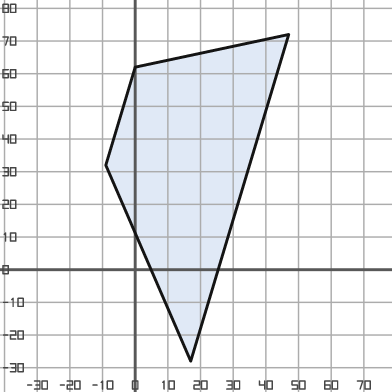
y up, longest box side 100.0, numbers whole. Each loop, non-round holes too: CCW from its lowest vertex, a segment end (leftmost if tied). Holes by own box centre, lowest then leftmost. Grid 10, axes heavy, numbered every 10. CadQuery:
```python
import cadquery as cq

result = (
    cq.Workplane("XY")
    .moveTo(17.0, -28.0)
    .lineTo(47.0, 72.0)
    .lineTo(0.0, 62.0)
    .lineTo(-9.0, 32.0)
    .close()
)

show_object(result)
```